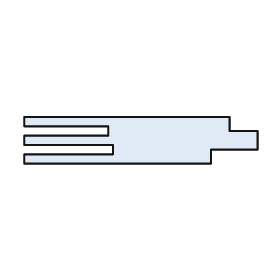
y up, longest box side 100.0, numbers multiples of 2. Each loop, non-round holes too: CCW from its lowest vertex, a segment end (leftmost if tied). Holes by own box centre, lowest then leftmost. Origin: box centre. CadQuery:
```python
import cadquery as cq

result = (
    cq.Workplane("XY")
    .moveTo(-50.0, -10.0)
    .lineTo(30.0, -10.0)
    .lineTo(30.0, -4.0)
    .lineTo(50.0, -4.0)
    .lineTo(50.0, 4.0)
    .lineTo(38.0, 4.0)
    .lineTo(38.0, 10.0)
    .lineTo(-50.0, 10.0)
    .lineTo(-50.0, 6.0)
    .lineTo(-14.0, 6.0)
    .lineTo(-14.0, 2.0)
    .lineTo(-50.0, 2.0)
    .lineTo(-50.0, -2.0)
    .lineTo(-12.0, -2.0)
    .lineTo(-12.0, -6.0)
    .lineTo(-50.0, -6.0)
    .close()
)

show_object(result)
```